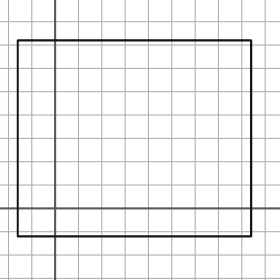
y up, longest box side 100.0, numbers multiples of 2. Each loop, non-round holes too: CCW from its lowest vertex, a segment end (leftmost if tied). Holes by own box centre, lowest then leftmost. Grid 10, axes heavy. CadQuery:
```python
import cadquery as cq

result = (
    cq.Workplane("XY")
    .moveTo(-16.0, -12.0)
    .lineTo(84.0, -12.0)
    .lineTo(84.0, 72.0)
    .lineTo(-16.0, 72.0)
    .close()
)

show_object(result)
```